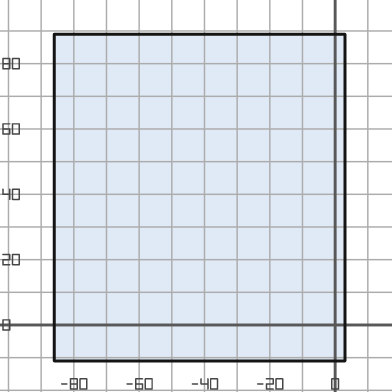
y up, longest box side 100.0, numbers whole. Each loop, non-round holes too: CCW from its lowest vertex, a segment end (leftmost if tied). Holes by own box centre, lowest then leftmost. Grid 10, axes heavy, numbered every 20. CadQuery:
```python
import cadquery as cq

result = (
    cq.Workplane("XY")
    .moveTo(-86.0, -11.0)
    .lineTo(3.0, -11.0)
    .lineTo(3.0, 89.0)
    .lineTo(-86.0, 89.0)
    .close()
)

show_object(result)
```